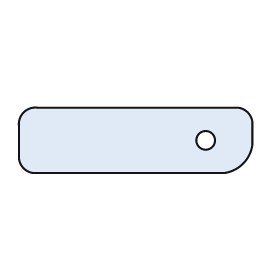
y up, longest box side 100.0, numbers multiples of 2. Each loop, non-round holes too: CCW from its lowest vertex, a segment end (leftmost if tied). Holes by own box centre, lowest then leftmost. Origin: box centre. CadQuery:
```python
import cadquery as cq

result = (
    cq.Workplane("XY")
    .moveTo(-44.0, -14.0)
    .lineTo(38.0, -14.0)
    .threePointArc((46.0, -10.0), (50.0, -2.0))
    .lineTo(50.0, 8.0)
    .threePointArc((48.0, 12.0), (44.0, 14.0))
    .lineTo(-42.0, 14.0)
    .threePointArc((-48.0, 12.0), (-50.0, 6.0))
    .lineTo(-50.0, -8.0)
    .threePointArc((-48.0, -12.0), (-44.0, -14.0))
    .close()
    .moveTo(30.0, 0.0)
    .circle(4.0)
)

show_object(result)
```